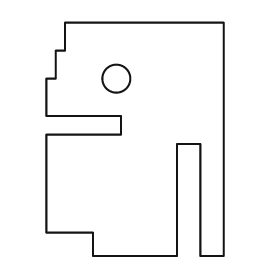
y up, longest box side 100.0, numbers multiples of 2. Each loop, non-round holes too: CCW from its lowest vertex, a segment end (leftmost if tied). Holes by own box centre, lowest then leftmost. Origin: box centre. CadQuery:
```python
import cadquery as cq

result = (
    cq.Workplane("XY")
    .moveTo(-18.0, -50.0)
    .lineTo(18.0, -50.0)
    .lineTo(18.0, -2.0)
    .lineTo(28.0, -2.0)
    .lineTo(28.0, -50.0)
    .lineTo(38.0, -50.0)
    .lineTo(38.0, 50.0)
    .lineTo(-30.0, 50.0)
    .lineTo(-30.0, 38.0)
    .lineTo(-34.0, 38.0)
    .lineTo(-34.0, 26.0)
    .lineTo(-38.0, 26.0)
    .lineTo(-38.0, 10.0)
    .lineTo(-6.0, 10.0)
    .lineTo(-6.0, 2.0)
    .lineTo(-38.0, 2.0)
    .lineTo(-38.0, -40.0)
    .lineTo(-18.0, -40.0)
    .close()
    .moveTo(-8.0, 26.0)
    .circle(6.0)
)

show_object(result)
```